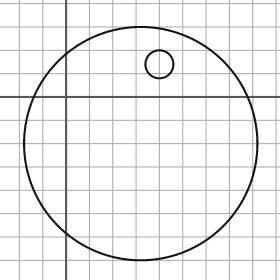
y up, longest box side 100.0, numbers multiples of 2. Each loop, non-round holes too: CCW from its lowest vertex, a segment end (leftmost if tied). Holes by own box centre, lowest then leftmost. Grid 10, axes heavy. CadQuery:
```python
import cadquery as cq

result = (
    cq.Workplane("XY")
    .moveTo(32.0, -20.0)
    .circle(50.0)
    .moveTo(40.0, 14.0)
    .circle(6.0)
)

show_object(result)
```